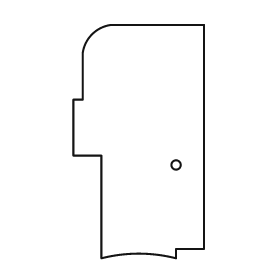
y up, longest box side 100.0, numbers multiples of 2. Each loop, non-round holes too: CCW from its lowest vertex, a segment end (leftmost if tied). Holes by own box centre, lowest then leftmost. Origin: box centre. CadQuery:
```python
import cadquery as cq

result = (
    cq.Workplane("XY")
    .moveTo(-16.0, -50.0)
    .threePointArc((0.0, -48.0), (16.0, -50.0))
    .lineTo(16.0, -46.0)
    .lineTo(28.0, -46.0)
    .lineTo(28.0, 50.0)
    .lineTo(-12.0, 50.0)
    .threePointArc((-20.0, 46.0), (-24.0, 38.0))
    .lineTo(-24.0, 18.0)
    .lineTo(-28.0, 18.0)
    .lineTo(-28.0, -6.0)
    .lineTo(-16.0, -6.0)
    .close()
    .moveTo(16.0, -10.0)
    .circle(2.0)
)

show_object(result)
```